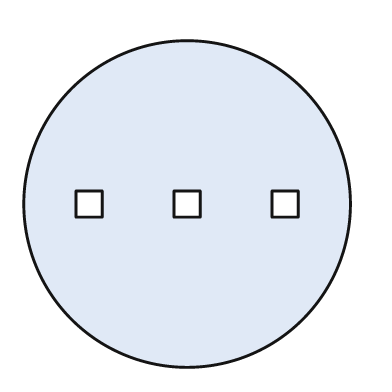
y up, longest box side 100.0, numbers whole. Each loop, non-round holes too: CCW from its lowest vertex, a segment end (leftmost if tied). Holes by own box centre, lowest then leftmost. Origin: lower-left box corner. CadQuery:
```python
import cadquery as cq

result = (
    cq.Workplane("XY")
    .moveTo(50.0, 50.0)
    .circle(50.0)
    .moveTo(16.0, 46.0)
    .lineTo(24.0, 46.0)
    .lineTo(24.0, 54.0)
    .lineTo(16.0, 54.0)
    .close()
    .moveTo(46.0, 46.0)
    .lineTo(54.0, 46.0)
    .lineTo(54.0, 54.0)
    .lineTo(46.0, 54.0)
    .close()
    .moveTo(76.0, 46.0)
    .lineTo(84.0, 46.0)
    .lineTo(84.0, 54.0)
    .lineTo(76.0, 54.0)
    .close()
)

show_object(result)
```